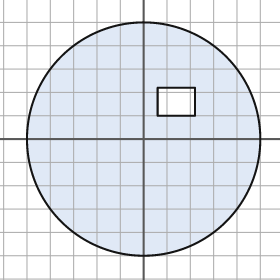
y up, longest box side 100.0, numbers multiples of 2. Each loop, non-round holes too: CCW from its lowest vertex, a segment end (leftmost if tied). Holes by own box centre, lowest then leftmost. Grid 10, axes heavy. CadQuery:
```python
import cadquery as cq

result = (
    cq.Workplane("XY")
    .moveTo(0.0, 0.0)
    .circle(50.0)
    .moveTo(6.0, 10.0)
    .lineTo(22.0, 10.0)
    .lineTo(22.0, 22.0)
    .lineTo(6.0, 22.0)
    .close()
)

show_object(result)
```